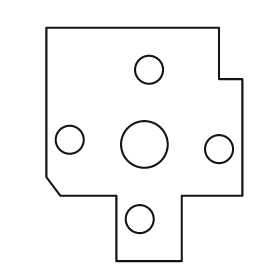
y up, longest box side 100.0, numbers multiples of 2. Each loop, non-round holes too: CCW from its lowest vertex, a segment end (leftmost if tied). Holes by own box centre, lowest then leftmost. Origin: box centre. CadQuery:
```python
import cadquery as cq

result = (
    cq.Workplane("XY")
    .moveTo(-12.0, -50.0)
    .lineTo(16.0, -50.0)
    .lineTo(16.0, -22.0)
    .lineTo(42.0, -22.0)
    .lineTo(42.0, 28.0)
    .lineTo(32.0, 28.0)
    .lineTo(32.0, 50.0)
    .lineTo(-42.0, 50.0)
    .lineTo(-42.0, -14.0)
    .lineTo(-36.0, -22.0)
    .lineTo(-12.0, -22.0)
    .close()
    .moveTo(-2.0, -32.0)
    .circle(6.0)
    .moveTo(32.0, -2.0)
    .circle(6.0)
    .moveTo(0.0, 0.0)
    .circle(10.0)
    .moveTo(-32.0, 2.0)
    .circle(6.0)
    .moveTo(2.0, 32.0)
    .circle(6.0)
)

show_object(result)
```